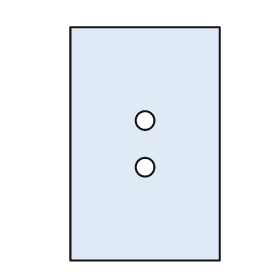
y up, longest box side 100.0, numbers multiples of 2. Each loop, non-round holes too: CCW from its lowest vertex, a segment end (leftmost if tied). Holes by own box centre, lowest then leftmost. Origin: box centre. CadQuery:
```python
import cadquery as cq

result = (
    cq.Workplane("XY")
    .moveTo(-32.0, -50.0)
    .lineTo(32.0, -50.0)
    .lineTo(32.0, 50.0)
    .lineTo(-32.0, 50.0)
    .close()
    .moveTo(0.0, -10.0)
    .circle(4.0)
    .moveTo(0.0, 10.0)
    .circle(4.0)
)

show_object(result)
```